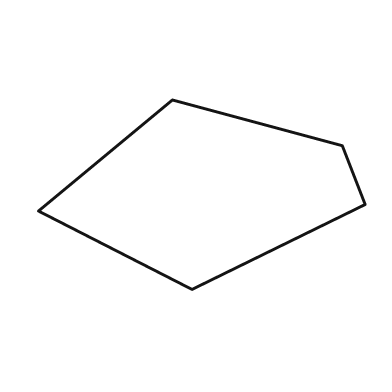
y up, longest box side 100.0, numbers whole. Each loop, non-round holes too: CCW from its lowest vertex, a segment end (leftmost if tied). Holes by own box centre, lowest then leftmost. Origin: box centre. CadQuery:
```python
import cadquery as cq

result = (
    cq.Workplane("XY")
    .moveTo(-3.0, -29.0)
    .lineTo(50.0, -3.0)
    .lineTo(43.0, 15.0)
    .lineTo(-9.0, 29.0)
    .lineTo(-50.0, -5.0)
    .close()
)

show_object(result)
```